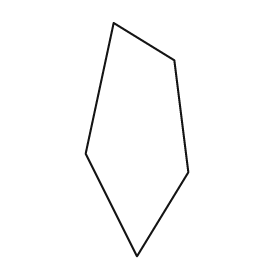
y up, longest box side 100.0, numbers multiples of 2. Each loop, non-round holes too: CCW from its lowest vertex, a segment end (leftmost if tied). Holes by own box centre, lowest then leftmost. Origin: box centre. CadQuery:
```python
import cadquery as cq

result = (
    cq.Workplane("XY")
    .moveTo(0.0, -50.0)
    .lineTo(22.0, -14.0)
    .lineTo(16.0, 34.0)
    .lineTo(-10.0, 50.0)
    .lineTo(-22.0, -6.0)
    .close()
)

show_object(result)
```